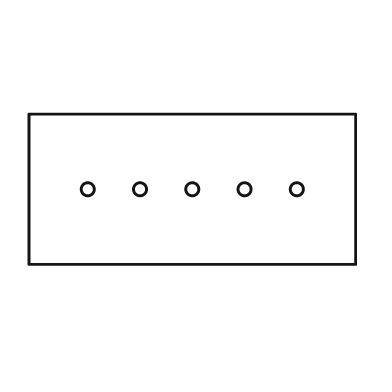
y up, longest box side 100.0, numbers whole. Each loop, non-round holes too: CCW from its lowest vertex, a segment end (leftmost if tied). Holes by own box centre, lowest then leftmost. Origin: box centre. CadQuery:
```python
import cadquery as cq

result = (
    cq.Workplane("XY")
    .moveTo(-50.0, -23.0)
    .lineTo(50.0, -23.0)
    .lineTo(50.0, 23.0)
    .lineTo(-50.0, 23.0)
    .close()
    .moveTo(-32.0, 0.0)
    .circle(2.0)
    .moveTo(-16.0, 0.0)
    .circle(2.0)
    .moveTo(0.0, 0.0)
    .circle(2.0)
    .moveTo(16.0, 0.0)
    .circle(2.0)
    .moveTo(32.0, 0.0)
    .circle(2.0)
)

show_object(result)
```